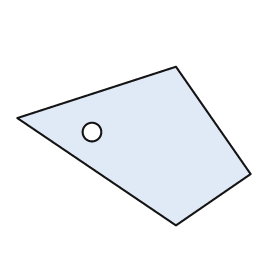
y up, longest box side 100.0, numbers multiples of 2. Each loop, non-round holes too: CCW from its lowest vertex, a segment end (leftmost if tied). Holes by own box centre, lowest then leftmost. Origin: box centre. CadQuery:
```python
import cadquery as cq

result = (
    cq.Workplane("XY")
    .moveTo(18.0, -34.0)
    .lineTo(50.0, -12.0)
    .lineTo(18.0, 34.0)
    .lineTo(-50.0, 12.0)
    .close()
    .moveTo(-18.0, 6.0)
    .circle(4.0)
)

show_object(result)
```